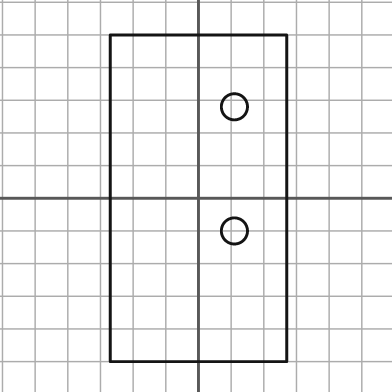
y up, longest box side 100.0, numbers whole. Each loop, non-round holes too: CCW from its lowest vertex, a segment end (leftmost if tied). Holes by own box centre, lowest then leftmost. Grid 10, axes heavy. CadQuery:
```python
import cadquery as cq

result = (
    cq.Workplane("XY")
    .moveTo(-27.0, -50.0)
    .lineTo(27.0, -50.0)
    .lineTo(27.0, 50.0)
    .lineTo(-27.0, 50.0)
    .close()
    .moveTo(11.0, -10.0)
    .circle(4.0)
    .moveTo(11.0, 28.0)
    .circle(4.0)
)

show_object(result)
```